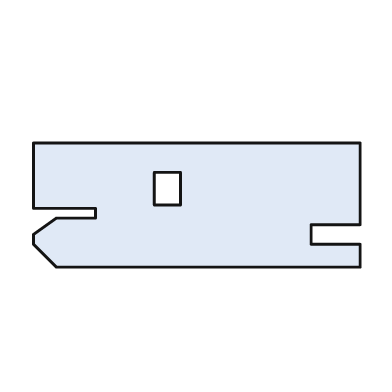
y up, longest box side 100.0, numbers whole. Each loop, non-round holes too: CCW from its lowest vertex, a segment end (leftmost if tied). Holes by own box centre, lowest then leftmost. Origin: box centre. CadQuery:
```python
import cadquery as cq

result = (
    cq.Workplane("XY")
    .moveTo(-43.0, -19.0)
    .lineTo(50.0, -19.0)
    .lineTo(50.0, -12.0)
    .lineTo(35.0, -12.0)
    .lineTo(35.0, -6.0)
    .lineTo(50.0, -6.0)
    .lineTo(50.0, 19.0)
    .lineTo(-50.0, 19.0)
    .lineTo(-50.0, -1.0)
    .lineTo(-31.0, -1.0)
    .lineTo(-31.0, -4.0)
    .lineTo(-43.0, -4.0)
    .lineTo(-50.0, -9.0)
    .lineTo(-50.0, -12.0)
    .close()
    .moveTo(-13.0, 0.0)
    .lineTo(-5.0, 0.0)
    .lineTo(-5.0, 10.0)
    .lineTo(-13.0, 10.0)
    .close()
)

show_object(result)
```